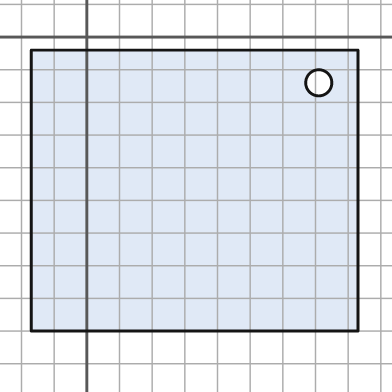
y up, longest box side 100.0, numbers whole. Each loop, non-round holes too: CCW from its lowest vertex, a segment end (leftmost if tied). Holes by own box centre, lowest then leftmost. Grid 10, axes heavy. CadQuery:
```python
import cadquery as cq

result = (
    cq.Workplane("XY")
    .moveTo(-17.0, -90.0)
    .lineTo(83.0, -90.0)
    .lineTo(83.0, -4.0)
    .lineTo(-17.0, -4.0)
    .close()
    .moveTo(71.0, -14.0)
    .circle(4.0)
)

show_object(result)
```